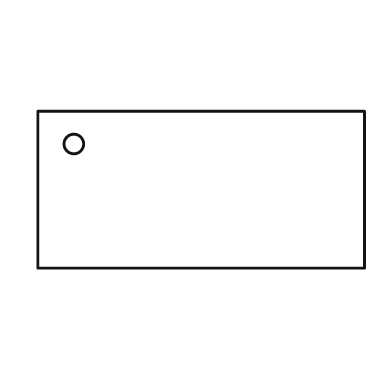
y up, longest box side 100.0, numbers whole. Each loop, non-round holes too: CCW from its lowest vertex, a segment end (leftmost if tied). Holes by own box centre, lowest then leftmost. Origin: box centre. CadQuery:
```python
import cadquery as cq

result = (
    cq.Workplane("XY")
    .moveTo(-50.0, -24.0)
    .lineTo(50.0, -24.0)
    .lineTo(50.0, 24.0)
    .lineTo(-50.0, 24.0)
    .close()
    .moveTo(-39.0, 14.0)
    .circle(3.0)
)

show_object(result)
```